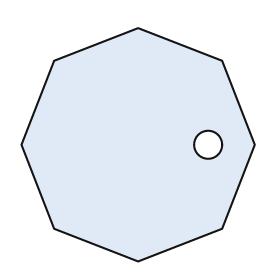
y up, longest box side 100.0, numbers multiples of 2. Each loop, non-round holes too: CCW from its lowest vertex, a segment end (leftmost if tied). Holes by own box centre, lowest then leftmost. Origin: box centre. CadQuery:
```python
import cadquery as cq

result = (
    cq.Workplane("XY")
    .moveTo(0.0, -50.0)
    .lineTo(36.0, -36.0)
    .lineTo(50.0, 0.0)
    .lineTo(36.0, 36.0)
    .lineTo(0.0, 50.0)
    .lineTo(-36.0, 36.0)
    .lineTo(-50.0, 0.0)
    .lineTo(-36.0, -36.0)
    .close()
    .moveTo(30.0, 0.0)
    .circle(6.0)
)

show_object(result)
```